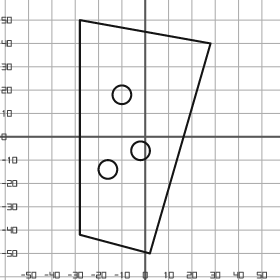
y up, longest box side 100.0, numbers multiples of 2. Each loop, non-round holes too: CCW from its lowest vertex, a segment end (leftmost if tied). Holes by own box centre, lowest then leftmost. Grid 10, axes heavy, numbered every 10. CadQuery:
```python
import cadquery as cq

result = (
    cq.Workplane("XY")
    .moveTo(2.0, -50.0)
    .lineTo(28.0, 40.0)
    .lineTo(-28.0, 50.0)
    .lineTo(-28.0, -42.0)
    .close()
    .moveTo(-16.0, -14.0)
    .circle(4.0)
    .moveTo(-2.0, -6.0)
    .circle(4.0)
    .moveTo(-10.0, 18.0)
    .circle(4.0)
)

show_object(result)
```